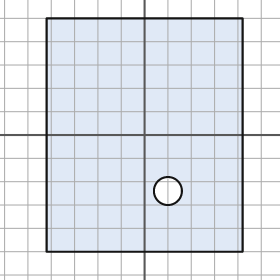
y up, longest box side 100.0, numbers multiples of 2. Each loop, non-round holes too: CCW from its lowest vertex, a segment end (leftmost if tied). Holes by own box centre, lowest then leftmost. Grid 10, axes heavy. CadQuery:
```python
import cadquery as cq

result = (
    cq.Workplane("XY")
    .moveTo(-42.0, -50.0)
    .lineTo(42.0, -50.0)
    .lineTo(42.0, 50.0)
    .lineTo(-42.0, 50.0)
    .close()
    .moveTo(10.0, -24.0)
    .circle(6.0)
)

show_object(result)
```